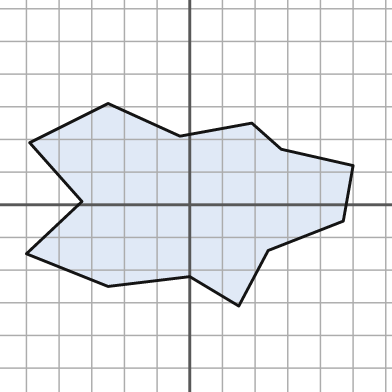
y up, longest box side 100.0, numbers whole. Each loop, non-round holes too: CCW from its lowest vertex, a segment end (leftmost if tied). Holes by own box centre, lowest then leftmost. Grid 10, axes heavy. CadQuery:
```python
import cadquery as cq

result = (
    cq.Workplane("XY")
    .moveTo(15.0, -31.0)
    .lineTo(24.0, -14.0)
    .lineTo(47.0, -5.0)
    .lineTo(50.0, 12.0)
    .lineTo(28.0, 17.0)
    .lineTo(19.0, 25.0)
    .lineTo(-3.0, 21.0)
    .lineTo(-25.0, 31.0)
    .lineTo(-49.0, 19.0)
    .lineTo(-33.0, 1.0)
    .lineTo(-50.0, -15.0)
    .lineTo(-25.0, -25.0)
    .lineTo(0.0, -22.0)
    .close()
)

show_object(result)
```